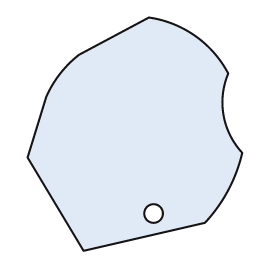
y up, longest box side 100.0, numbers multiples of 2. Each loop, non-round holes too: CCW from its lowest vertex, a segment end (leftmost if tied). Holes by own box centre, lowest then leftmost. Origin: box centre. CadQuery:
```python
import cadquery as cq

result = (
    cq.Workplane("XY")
    .moveTo(-22.0, -50.0)
    .lineTo(30.0, -38.0)
    .threePointArc((40.0, -24.0), (46.0, -8.0))
    .threePointArc((38.0, 8.0), (40.0, 26.0))
    .threePointArc((26.0, 42.0), (6.0, 50.0))
    .lineTo(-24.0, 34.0)
    .threePointArc((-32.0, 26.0), (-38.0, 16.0))
    .lineTo(-46.0, -10.0)
    .close()
    .moveTo(8.0, -34.0)
    .circle(4.0)
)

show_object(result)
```